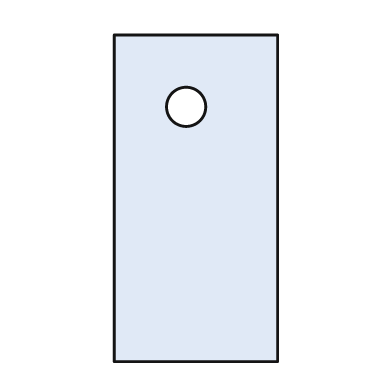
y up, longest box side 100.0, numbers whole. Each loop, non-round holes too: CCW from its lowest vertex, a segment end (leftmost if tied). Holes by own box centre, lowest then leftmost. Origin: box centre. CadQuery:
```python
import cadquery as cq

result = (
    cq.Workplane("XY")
    .moveTo(-25.0, -50.0)
    .lineTo(25.0, -50.0)
    .lineTo(25.0, 50.0)
    .lineTo(-25.0, 50.0)
    .close()
    .moveTo(-3.0, 28.0)
    .circle(6.0)
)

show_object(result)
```